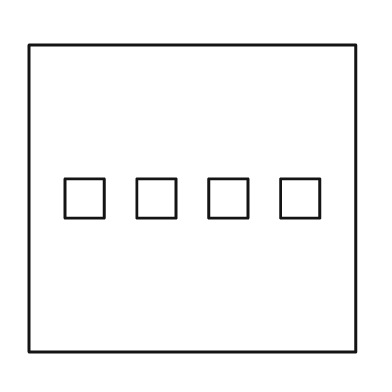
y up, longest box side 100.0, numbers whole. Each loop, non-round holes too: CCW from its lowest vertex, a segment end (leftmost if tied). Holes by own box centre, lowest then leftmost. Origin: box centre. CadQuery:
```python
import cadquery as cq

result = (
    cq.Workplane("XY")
    .moveTo(-50.0, -47.0)
    .lineTo(50.0, -47.0)
    .lineTo(50.0, 47.0)
    .lineTo(-50.0, 47.0)
    .close()
    .moveTo(-39.0, -6.0)
    .lineTo(-27.0, -6.0)
    .lineTo(-27.0, 6.0)
    .lineTo(-39.0, 6.0)
    .close()
    .moveTo(-17.0, -6.0)
    .lineTo(-5.0, -6.0)
    .lineTo(-5.0, 6.0)
    .lineTo(-17.0, 6.0)
    .close()
    .moveTo(5.0, -6.0)
    .lineTo(17.0, -6.0)
    .lineTo(17.0, 6.0)
    .lineTo(5.0, 6.0)
    .close()
    .moveTo(27.0, -6.0)
    .lineTo(39.0, -6.0)
    .lineTo(39.0, 6.0)
    .lineTo(27.0, 6.0)
    .close()
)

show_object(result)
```